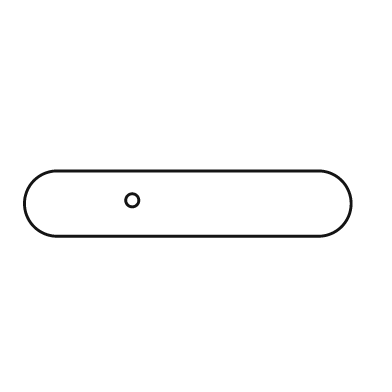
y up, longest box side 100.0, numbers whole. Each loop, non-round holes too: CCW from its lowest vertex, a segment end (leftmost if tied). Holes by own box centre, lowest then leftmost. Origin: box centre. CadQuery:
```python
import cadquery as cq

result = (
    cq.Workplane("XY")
    .moveTo(-40.0, -10.0)
    .lineTo(40.0, -10.0)
    .threePointArc((50.0, 0.0), (40.0, 10.0))
    .lineTo(-40.0, 10.0)
    .threePointArc((-50.0, 0.0), (-40.0, -10.0))
    .close()
    .moveTo(-17.0, 1.0)
    .circle(2.0)
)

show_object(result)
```